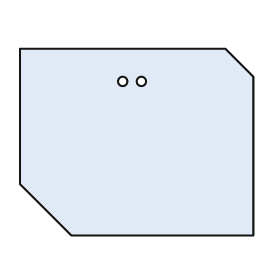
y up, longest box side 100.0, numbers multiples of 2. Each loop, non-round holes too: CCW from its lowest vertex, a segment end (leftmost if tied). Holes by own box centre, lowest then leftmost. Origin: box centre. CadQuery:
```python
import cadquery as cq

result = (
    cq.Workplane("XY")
    .moveTo(-28.0, -40.0)
    .lineTo(50.0, -40.0)
    .lineTo(50.0, 28.0)
    .lineTo(38.0, 40.0)
    .lineTo(-50.0, 40.0)
    .lineTo(-50.0, -18.0)
    .close()
    .moveTo(-6.0, 26.0)
    .circle(2.0)
    .moveTo(2.0, 26.0)
    .circle(2.0)
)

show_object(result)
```